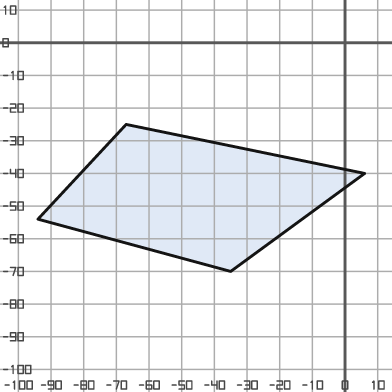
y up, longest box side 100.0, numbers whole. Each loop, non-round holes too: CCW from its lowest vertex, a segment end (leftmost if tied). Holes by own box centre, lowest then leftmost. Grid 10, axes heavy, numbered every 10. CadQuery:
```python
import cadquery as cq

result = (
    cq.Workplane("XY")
    .moveTo(-35.0, -70.0)
    .lineTo(6.0, -40.0)
    .lineTo(-67.0, -25.0)
    .lineTo(-94.0, -54.0)
    .close()
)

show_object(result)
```